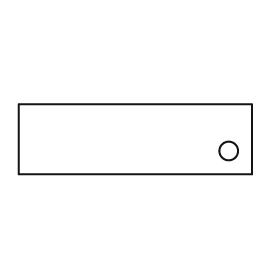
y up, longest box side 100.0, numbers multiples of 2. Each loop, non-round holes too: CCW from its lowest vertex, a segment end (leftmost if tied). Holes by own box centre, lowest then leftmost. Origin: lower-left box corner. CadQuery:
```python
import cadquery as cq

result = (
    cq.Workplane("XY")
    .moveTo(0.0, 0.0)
    .lineTo(100.0, 0.0)
    .lineTo(100.0, 30.0)
    .lineTo(0.0, 30.0)
    .close()
    .moveTo(90.0, 10.0)
    .circle(4.0)
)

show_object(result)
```